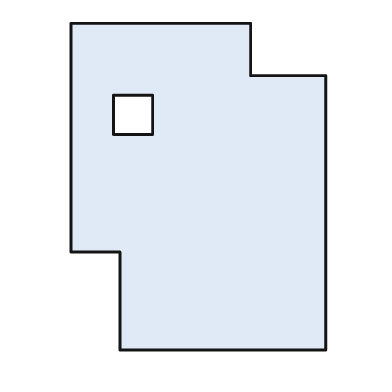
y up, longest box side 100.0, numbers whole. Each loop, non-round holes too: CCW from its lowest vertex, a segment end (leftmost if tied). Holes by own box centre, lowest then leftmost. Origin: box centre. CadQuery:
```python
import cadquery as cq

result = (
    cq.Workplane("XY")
    .moveTo(-24.0, -50.0)
    .lineTo(39.0, -50.0)
    .lineTo(39.0, 34.0)
    .lineTo(16.0, 34.0)
    .lineTo(16.0, 50.0)
    .lineTo(-39.0, 50.0)
    .lineTo(-39.0, -20.0)
    .lineTo(-24.0, -20.0)
    .close()
    .moveTo(-26.0, 16.0)
    .lineTo(-14.0, 16.0)
    .lineTo(-14.0, 28.0)
    .lineTo(-26.0, 28.0)
    .close()
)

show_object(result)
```